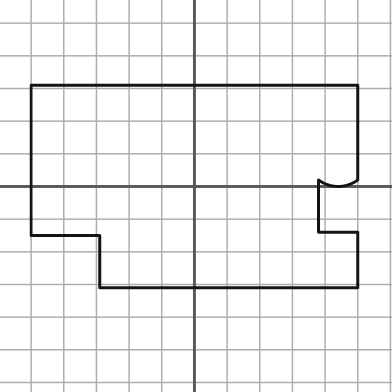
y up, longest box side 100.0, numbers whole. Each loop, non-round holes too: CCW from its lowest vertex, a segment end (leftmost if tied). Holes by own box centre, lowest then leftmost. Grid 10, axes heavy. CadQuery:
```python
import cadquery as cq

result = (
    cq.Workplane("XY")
    .moveTo(-29.0, -31.0)
    .lineTo(50.0, -31.0)
    .lineTo(50.0, -14.0)
    .lineTo(38.0, -14.0)
    .lineTo(38.0, 2.0)
    .threePointArc((44.0, 0.0), (50.0, 2.0))
    .lineTo(50.0, 31.0)
    .lineTo(-50.0, 31.0)
    .lineTo(-50.0, -15.0)
    .lineTo(-29.0, -15.0)
    .close()
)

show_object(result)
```